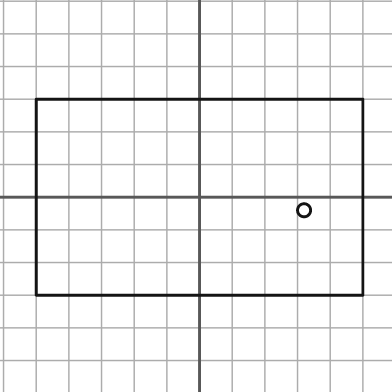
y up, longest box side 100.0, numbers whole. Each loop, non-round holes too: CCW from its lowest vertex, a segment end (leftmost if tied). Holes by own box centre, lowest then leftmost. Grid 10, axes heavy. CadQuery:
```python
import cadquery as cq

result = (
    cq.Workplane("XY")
    .moveTo(-50.0, -30.0)
    .lineTo(50.0, -30.0)
    .lineTo(50.0, 30.0)
    .lineTo(-50.0, 30.0)
    .close()
    .moveTo(32.0, -4.0)
    .circle(2.0)
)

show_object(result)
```